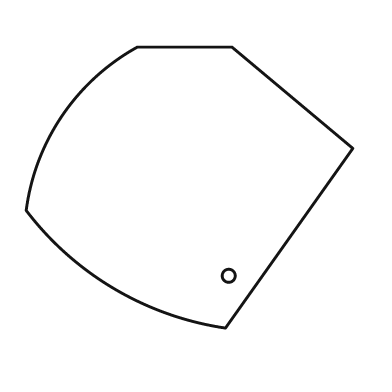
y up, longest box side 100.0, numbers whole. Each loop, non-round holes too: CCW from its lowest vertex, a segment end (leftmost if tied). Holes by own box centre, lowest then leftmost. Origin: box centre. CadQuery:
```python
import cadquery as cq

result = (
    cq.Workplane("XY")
    .moveTo(11.0, -43.0)
    .lineTo(50.0, 12.0)
    .lineTo(13.0, 43.0)
    .lineTo(-16.0, 43.0)
    .threePointArc((-39.0, 22.0), (-50.0, -7.0))
    .threePointArc((-23.0, -31.0), (11.0, -43.0))
    .close()
    .moveTo(12.0, -27.0)
    .circle(2.0)
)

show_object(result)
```